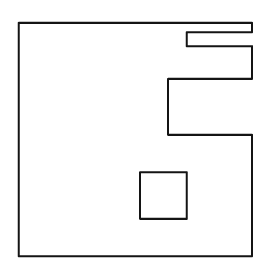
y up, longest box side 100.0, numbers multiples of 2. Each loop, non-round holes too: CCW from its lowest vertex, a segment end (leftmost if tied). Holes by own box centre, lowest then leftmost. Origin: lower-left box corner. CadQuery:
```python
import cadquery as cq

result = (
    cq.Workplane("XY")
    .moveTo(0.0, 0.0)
    .lineTo(100.0, 0.0)
    .lineTo(100.0, 52.0)
    .lineTo(64.0, 52.0)
    .lineTo(64.0, 76.0)
    .lineTo(100.0, 76.0)
    .lineTo(100.0, 90.0)
    .lineTo(72.0, 90.0)
    .lineTo(72.0, 96.0)
    .lineTo(100.0, 96.0)
    .lineTo(100.0, 100.0)
    .lineTo(0.0, 100.0)
    .close()
    .moveTo(52.0, 16.0)
    .lineTo(72.0, 16.0)
    .lineTo(72.0, 36.0)
    .lineTo(52.0, 36.0)
    .close()
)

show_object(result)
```